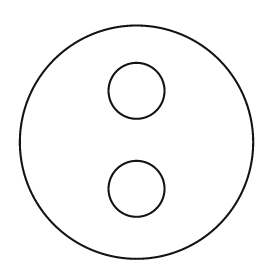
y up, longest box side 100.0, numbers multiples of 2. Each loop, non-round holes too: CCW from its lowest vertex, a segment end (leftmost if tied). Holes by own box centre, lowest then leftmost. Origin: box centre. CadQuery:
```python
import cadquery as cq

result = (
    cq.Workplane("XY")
    .moveTo(0.0, 0.0)
    .circle(50.0)
    .moveTo(0.0, -20.0)
    .circle(12.0)
    .moveTo(0.0, 22.0)
    .circle(12.0)
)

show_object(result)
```